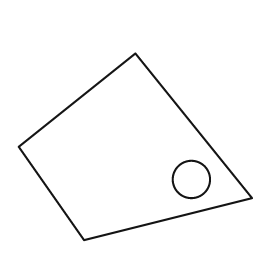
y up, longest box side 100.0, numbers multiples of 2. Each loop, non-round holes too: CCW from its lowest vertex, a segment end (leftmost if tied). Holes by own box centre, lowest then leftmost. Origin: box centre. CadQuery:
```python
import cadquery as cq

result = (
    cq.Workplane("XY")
    .moveTo(-22.0, -40.0)
    .lineTo(50.0, -22.0)
    .lineTo(0.0, 40.0)
    .lineTo(-50.0, 0.0)
    .close()
    .moveTo(24.0, -14.0)
    .circle(8.0)
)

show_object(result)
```